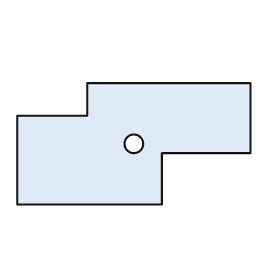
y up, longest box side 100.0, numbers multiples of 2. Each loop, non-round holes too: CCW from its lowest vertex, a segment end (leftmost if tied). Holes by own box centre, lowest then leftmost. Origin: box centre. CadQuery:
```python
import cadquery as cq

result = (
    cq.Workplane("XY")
    .moveTo(-50.0, -26.0)
    .lineTo(12.0, -26.0)
    .lineTo(12.0, -4.0)
    .lineTo(50.0, -4.0)
    .lineTo(50.0, 26.0)
    .lineTo(-20.0, 26.0)
    .lineTo(-20.0, 12.0)
    .lineTo(-50.0, 12.0)
    .close()
    .moveTo(0.0, 0.0)
    .circle(4.0)
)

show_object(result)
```